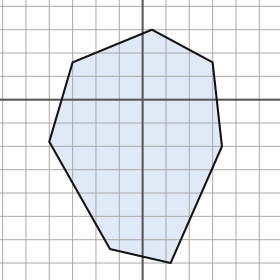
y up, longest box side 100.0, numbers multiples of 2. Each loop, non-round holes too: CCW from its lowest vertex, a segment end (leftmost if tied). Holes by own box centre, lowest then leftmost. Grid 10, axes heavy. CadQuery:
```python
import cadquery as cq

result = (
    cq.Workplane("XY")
    .moveTo(12.0, -70.0)
    .lineTo(34.0, -20.0)
    .lineTo(30.0, 16.0)
    .lineTo(4.0, 30.0)
    .lineTo(-30.0, 16.0)
    .lineTo(-40.0, -18.0)
    .lineTo(-14.0, -64.0)
    .close()
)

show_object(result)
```